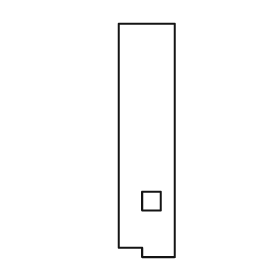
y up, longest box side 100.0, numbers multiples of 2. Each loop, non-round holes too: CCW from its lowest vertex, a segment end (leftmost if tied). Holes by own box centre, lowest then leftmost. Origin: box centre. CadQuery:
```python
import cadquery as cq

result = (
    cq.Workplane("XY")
    .moveTo(-2.0, -50.0)
    .lineTo(12.0, -50.0)
    .lineTo(12.0, 50.0)
    .lineTo(-12.0, 50.0)
    .lineTo(-12.0, -46.0)
    .lineTo(-2.0, -46.0)
    .close()
    .moveTo(-2.0, -30.0)
    .lineTo(6.0, -30.0)
    .lineTo(6.0, -22.0)
    .lineTo(-2.0, -22.0)
    .close()
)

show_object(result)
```